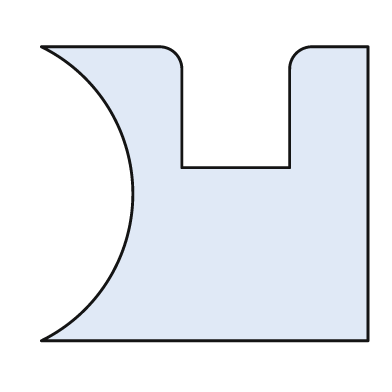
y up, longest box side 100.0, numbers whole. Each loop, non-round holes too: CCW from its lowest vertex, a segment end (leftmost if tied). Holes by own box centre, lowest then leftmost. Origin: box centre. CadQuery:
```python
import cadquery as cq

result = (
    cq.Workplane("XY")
    .moveTo(-50.0, -45.0)
    .lineTo(50.0, -45.0)
    .lineTo(50.0, 45.0)
    .lineTo(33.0, 45.0)
    .threePointArc((28.0, 43.0), (26.0, 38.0))
    .lineTo(26.0, 8.0)
    .lineTo(-7.0, 8.0)
    .lineTo(-7.0, 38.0)
    .threePointArc((-9.0, 43.0), (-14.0, 45.0))
    .lineTo(-50.0, 45.0)
    .threePointArc((-22.0, 0.0), (-50.0, -45.0))
    .close()
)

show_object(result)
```